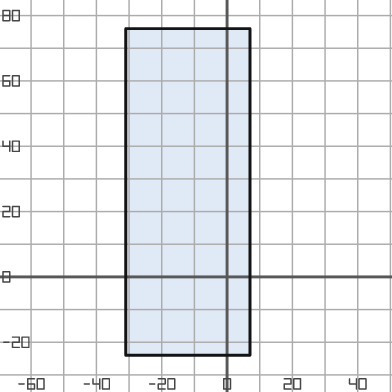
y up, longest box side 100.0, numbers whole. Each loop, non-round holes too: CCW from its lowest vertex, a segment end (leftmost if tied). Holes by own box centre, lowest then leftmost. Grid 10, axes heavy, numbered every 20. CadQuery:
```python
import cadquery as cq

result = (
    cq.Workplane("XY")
    .moveTo(-31.0, -24.0)
    .lineTo(7.0, -24.0)
    .lineTo(7.0, 76.0)
    .lineTo(-31.0, 76.0)
    .close()
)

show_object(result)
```